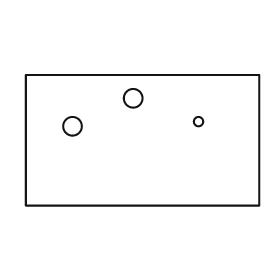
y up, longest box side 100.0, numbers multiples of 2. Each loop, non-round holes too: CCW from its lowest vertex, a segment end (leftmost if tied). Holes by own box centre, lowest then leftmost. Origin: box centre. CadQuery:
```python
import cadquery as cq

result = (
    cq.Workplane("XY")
    .moveTo(-50.0, -28.0)
    .lineTo(50.0, -28.0)
    .lineTo(50.0, 28.0)
    .lineTo(-50.0, 28.0)
    .close()
    .moveTo(-30.0, 6.0)
    .circle(4.0)
    .moveTo(24.0, 8.0)
    .circle(2.0)
    .moveTo(-4.0, 18.0)
    .circle(4.0)
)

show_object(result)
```